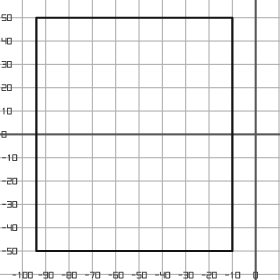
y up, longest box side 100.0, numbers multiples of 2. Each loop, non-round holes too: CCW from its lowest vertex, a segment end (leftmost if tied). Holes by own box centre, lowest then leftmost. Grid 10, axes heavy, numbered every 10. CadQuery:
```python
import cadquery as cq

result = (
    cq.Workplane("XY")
    .moveTo(-94.0, -50.0)
    .lineTo(-10.0, -50.0)
    .lineTo(-10.0, 50.0)
    .lineTo(-94.0, 50.0)
    .close()
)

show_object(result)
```